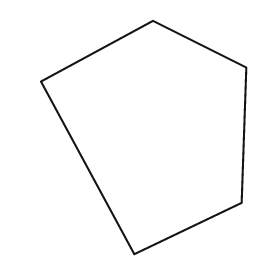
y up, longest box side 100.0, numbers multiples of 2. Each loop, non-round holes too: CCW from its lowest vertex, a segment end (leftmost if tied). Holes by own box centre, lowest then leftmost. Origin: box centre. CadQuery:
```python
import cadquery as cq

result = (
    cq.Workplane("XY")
    .moveTo(-4.0, -50.0)
    .lineTo(42.0, -28.0)
    .lineTo(44.0, 30.0)
    .lineTo(4.0, 50.0)
    .lineTo(-44.0, 24.0)
    .close()
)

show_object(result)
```